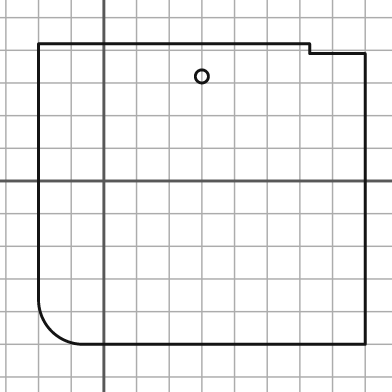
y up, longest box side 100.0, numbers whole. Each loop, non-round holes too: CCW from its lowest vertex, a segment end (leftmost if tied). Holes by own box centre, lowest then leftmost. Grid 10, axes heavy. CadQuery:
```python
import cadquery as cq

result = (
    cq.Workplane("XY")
    .moveTo(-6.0, -50.0)
    .lineTo(80.0, -50.0)
    .lineTo(80.0, 39.0)
    .lineTo(63.0, 39.0)
    .lineTo(63.0, 42.0)
    .lineTo(-20.0, 42.0)
    .lineTo(-20.0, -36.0)
    .threePointArc((-16.0, -46.0), (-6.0, -50.0))
    .close()
    .moveTo(30.0, 32.0)
    .circle(2.0)
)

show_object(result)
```